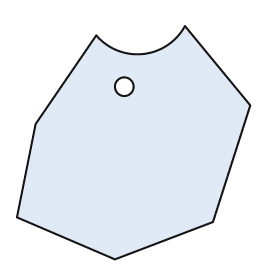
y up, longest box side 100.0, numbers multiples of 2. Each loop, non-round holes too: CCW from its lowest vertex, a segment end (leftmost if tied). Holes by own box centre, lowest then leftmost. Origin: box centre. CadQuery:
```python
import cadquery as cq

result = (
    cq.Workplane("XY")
    .moveTo(-8.0, -50.0)
    .lineTo(34.0, -34.0)
    .lineTo(50.0, 16.0)
    .lineTo(22.0, 50.0)
    .threePointArc((4.0, 38.0), (-16.0, 46.0))
    .lineTo(-42.0, 8.0)
    .lineTo(-50.0, -32.0)
    .close()
    .moveTo(-4.0, 24.0)
    .circle(4.0)
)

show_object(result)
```